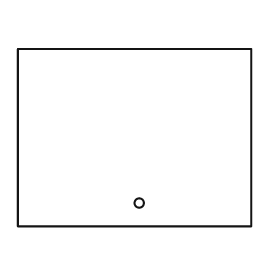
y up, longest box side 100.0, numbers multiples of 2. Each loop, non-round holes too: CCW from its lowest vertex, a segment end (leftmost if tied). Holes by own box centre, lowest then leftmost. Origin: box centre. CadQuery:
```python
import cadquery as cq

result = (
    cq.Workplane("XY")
    .moveTo(-50.0, -38.0)
    .lineTo(50.0, -38.0)
    .lineTo(50.0, 38.0)
    .lineTo(-50.0, 38.0)
    .close()
    .moveTo(2.0, -28.0)
    .circle(2.0)
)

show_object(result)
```